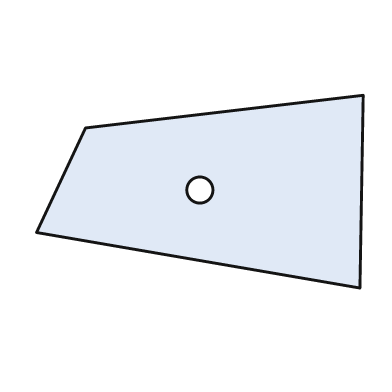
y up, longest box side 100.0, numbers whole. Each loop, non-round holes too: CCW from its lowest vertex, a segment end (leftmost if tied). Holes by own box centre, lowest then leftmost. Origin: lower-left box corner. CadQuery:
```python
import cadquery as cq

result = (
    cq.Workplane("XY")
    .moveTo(99.0, 0.0)
    .lineTo(100.0, 59.0)
    .lineTo(15.0, 49.0)
    .lineTo(0.0, 17.0)
    .close()
    .moveTo(50.0, 30.0)
    .circle(4.0)
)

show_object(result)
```